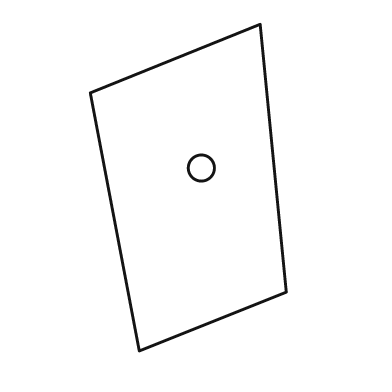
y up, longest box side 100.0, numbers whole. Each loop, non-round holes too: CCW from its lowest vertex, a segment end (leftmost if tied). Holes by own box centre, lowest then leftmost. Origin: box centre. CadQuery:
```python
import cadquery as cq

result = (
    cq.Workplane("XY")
    .moveTo(-15.0, -50.0)
    .lineTo(30.0, -32.0)
    .lineTo(22.0, 50.0)
    .lineTo(-30.0, 29.0)
    .close()
    .moveTo(4.0, 6.0)
    .circle(4.0)
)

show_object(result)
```